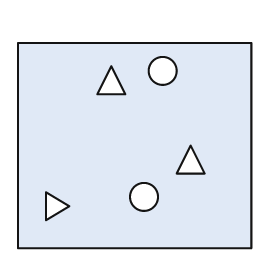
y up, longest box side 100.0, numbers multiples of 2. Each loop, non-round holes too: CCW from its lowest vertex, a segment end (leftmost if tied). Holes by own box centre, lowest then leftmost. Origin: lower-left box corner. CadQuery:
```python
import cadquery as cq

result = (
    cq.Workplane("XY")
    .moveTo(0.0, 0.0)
    .lineTo(100.0, 0.0)
    .lineTo(100.0, 88.0)
    .lineTo(0.0, 88.0)
    .close()
    .moveTo(12.0, 12.0)
    .lineTo(22.0, 18.0)
    .lineTo(12.0, 24.0)
    .close()
    .moveTo(54.0, 22.0)
    .circle(6.0)
    .moveTo(68.0, 32.0)
    .lineTo(80.0, 32.0)
    .lineTo(74.0, 44.0)
    .close()
    .moveTo(34.0, 66.0)
    .lineTo(46.0, 66.0)
    .lineTo(40.0, 78.0)
    .close()
    .moveTo(62.0, 76.0)
    .circle(6.0)
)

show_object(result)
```